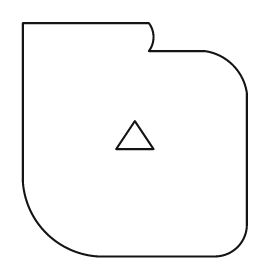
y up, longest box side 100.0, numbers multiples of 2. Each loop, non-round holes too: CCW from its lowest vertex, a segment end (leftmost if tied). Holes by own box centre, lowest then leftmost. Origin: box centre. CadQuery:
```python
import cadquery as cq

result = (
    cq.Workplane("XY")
    .moveTo(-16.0, -50.0)
    .lineTo(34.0, -50.0)
    .threePointArc((44.0, -46.0), (48.0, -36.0))
    .lineTo(48.0, 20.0)
    .threePointArc((42.0, 32.0), (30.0, 38.0))
    .lineTo(6.0, 38.0)
    .threePointArc((8.0, 44.0), (6.0, 50.0))
    .lineTo(-48.0, 50.0)
    .lineTo(-48.0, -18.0)
    .threePointArc((-38.0, -40.0), (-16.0, -50.0))
    .close()
    .moveTo(-8.0, -4.0)
    .lineTo(8.0, -4.0)
    .lineTo(0.0, 8.0)
    .close()
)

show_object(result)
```